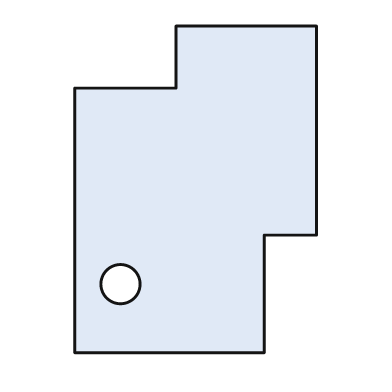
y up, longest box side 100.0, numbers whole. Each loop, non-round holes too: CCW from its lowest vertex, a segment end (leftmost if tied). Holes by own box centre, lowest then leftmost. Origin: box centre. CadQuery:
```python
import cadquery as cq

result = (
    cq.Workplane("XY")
    .moveTo(-37.0, -50.0)
    .lineTo(21.0, -50.0)
    .lineTo(21.0, -14.0)
    .lineTo(37.0, -14.0)
    .lineTo(37.0, 50.0)
    .lineTo(-6.0, 50.0)
    .lineTo(-6.0, 31.0)
    .lineTo(-37.0, 31.0)
    .close()
    .moveTo(-23.0, -29.0)
    .circle(6.0)
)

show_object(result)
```